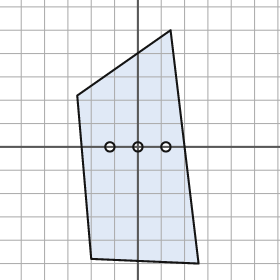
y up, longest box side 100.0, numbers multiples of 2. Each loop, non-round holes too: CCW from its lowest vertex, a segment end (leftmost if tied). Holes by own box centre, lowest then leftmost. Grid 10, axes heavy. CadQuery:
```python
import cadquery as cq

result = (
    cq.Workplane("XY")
    .moveTo(26.0, -50.0)
    .lineTo(14.0, 50.0)
    .lineTo(-26.0, 22.0)
    .lineTo(-20.0, -48.0)
    .close()
    .moveTo(-12.0, 0.0)
    .circle(2.0)
    .moveTo(0.0, 0.0)
    .circle(2.0)
    .moveTo(12.0, 0.0)
    .circle(2.0)
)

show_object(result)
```